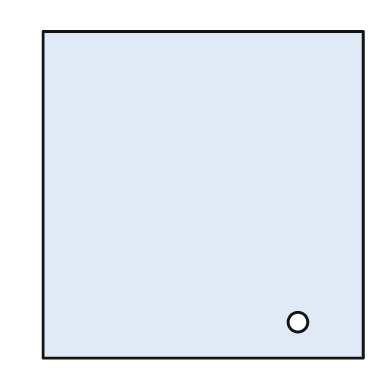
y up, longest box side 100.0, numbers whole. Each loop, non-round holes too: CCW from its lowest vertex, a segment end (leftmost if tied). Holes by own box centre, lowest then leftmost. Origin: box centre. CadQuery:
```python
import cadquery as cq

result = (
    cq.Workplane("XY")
    .moveTo(-49.0, -50.0)
    .lineTo(49.0, -50.0)
    .lineTo(49.0, 50.0)
    .lineTo(-49.0, 50.0)
    .close()
    .moveTo(29.0, -39.0)
    .circle(3.0)
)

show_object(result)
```